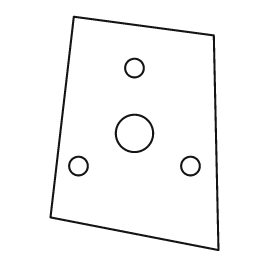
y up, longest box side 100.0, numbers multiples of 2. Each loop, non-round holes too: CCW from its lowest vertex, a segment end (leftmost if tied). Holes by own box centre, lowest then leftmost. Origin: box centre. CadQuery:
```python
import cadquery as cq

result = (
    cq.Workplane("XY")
    .moveTo(36.0, -50.0)
    .lineTo(34.0, 42.0)
    .lineTo(-26.0, 50.0)
    .lineTo(-36.0, -36.0)
    .close()
    .moveTo(-24.0, -14.0)
    .circle(4.0)
    .moveTo(24.0, -14.0)
    .circle(4.0)
    .moveTo(0.0, 0.0)
    .circle(8.0)
    .moveTo(0.0, 28.0)
    .circle(4.0)
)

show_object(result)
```